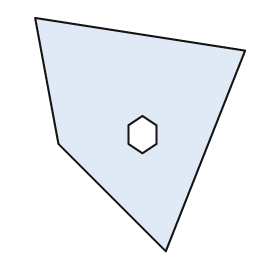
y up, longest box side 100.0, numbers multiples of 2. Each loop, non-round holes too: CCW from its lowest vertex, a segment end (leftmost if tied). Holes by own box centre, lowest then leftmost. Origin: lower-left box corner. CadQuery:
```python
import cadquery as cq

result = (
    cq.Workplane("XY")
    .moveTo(56.0, 0.0)
    .lineTo(90.0, 86.0)
    .lineTo(0.0, 100.0)
    .lineTo(10.0, 46.0)
    .close()
    .moveTo(46.0, 42.0)
    .lineTo(52.0, 46.0)
    .lineTo(52.0, 54.0)
    .lineTo(46.0, 58.0)
    .lineTo(40.0, 54.0)
    .lineTo(40.0, 46.0)
    .close()
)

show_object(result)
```